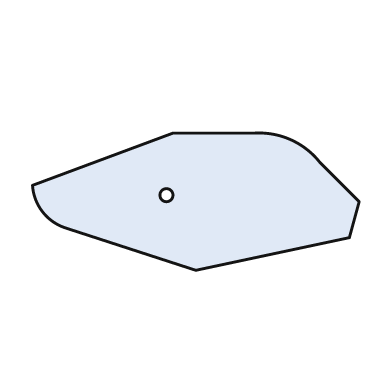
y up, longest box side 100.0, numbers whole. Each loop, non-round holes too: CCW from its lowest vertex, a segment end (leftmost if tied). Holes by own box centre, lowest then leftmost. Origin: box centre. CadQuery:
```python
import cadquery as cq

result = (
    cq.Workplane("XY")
    .moveTo(0.0, -21.0)
    .lineTo(47.0, -11.0)
    .lineTo(50.0, 0.0)
    .lineTo(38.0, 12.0)
    .threePointArc((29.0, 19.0), (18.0, 21.0))
    .lineTo(-7.0, 21.0)
    .lineTo(-50.0, 5.0)
    .threePointArc((-47.0, -3.0), (-40.0, -8.0))
    .close()
    .moveTo(-9.0, 2.0)
    .circle(2.0)
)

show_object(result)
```